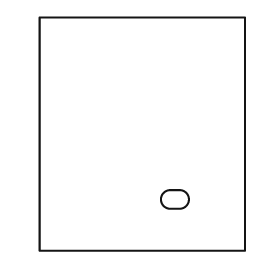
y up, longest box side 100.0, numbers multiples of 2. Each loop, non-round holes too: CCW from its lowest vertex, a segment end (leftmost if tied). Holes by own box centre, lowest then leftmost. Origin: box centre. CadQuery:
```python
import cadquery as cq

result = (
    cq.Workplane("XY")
    .moveTo(-44.0, -50.0)
    .lineTo(44.0, -50.0)
    .lineTo(44.0, 50.0)
    .lineTo(-44.0, 50.0)
    .close()
    .moveTo(12.0, -32.0)
    .lineTo(16.0, -32.0)
    .threePointArc((20.0, -28.0), (16.0, -24.0))
    .lineTo(12.0, -24.0)
    .threePointArc((8.0, -28.0), (12.0, -32.0))
    .close()
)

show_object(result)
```